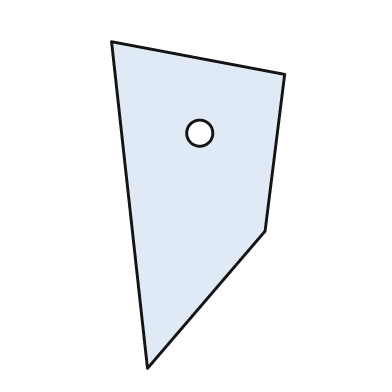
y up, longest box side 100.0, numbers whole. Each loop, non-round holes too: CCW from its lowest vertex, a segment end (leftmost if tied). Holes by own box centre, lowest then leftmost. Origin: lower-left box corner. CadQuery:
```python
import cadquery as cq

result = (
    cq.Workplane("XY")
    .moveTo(11.0, 0.0)
    .lineTo(47.0, 42.0)
    .lineTo(53.0, 90.0)
    .lineTo(0.0, 100.0)
    .close()
    .moveTo(27.0, 72.0)
    .circle(4.0)
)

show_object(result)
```